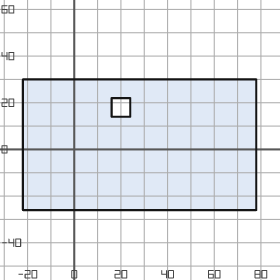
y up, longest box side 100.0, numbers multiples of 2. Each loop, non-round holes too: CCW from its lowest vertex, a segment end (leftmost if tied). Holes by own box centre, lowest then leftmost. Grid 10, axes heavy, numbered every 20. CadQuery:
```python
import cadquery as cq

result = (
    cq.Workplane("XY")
    .moveTo(-22.0, -26.0)
    .lineTo(78.0, -26.0)
    .lineTo(78.0, 30.0)
    .lineTo(-22.0, 30.0)
    .close()
    .moveTo(16.0, 14.0)
    .lineTo(24.0, 14.0)
    .lineTo(24.0, 22.0)
    .lineTo(16.0, 22.0)
    .close()
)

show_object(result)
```